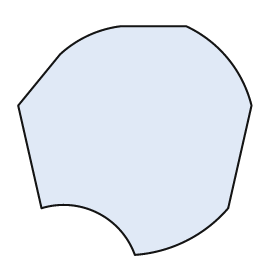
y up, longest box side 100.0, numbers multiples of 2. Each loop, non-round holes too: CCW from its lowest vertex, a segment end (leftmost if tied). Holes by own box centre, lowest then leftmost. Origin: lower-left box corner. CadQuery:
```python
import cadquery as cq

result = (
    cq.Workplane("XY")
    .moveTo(50.0, 0.0)
    .threePointArc((72.0, 6.0), (90.0, 20.0))
    .lineTo(100.0, 64.0)
    .threePointArc((90.0, 84.0), (72.0, 98.0))
    .lineTo(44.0, 98.0)
    .threePointArc((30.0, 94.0), (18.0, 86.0))
    .lineTo(0.0, 64.0)
    .lineTo(10.0, 20.0)
    .threePointArc((34.0, 18.0), (50.0, 0.0))
    .close()
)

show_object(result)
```